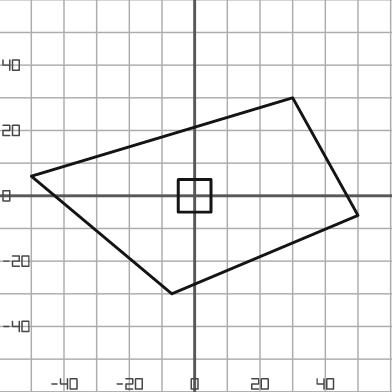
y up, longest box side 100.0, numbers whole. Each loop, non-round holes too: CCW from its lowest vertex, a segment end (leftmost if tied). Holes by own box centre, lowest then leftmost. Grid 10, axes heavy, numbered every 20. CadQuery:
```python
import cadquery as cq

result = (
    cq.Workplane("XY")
    .moveTo(-7.0, -30.0)
    .lineTo(50.0, -6.0)
    .lineTo(30.0, 30.0)
    .lineTo(-50.0, 6.0)
    .close()
    .moveTo(-5.0, -5.0)
    .lineTo(5.0, -5.0)
    .lineTo(5.0, 5.0)
    .lineTo(-5.0, 5.0)
    .close()
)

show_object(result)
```